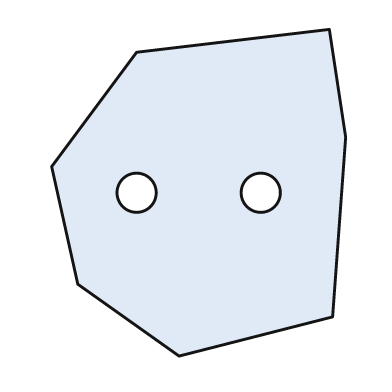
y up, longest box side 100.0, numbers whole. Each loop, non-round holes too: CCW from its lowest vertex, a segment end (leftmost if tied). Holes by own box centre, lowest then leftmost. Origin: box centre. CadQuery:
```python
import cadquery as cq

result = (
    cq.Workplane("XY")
    .moveTo(-6.0, -50.0)
    .lineTo(41.0, -38.0)
    .lineTo(45.0, 17.0)
    .lineTo(40.0, 50.0)
    .lineTo(-19.0, 43.0)
    .lineTo(-45.0, 8.0)
    .lineTo(-37.0, -28.0)
    .close()
    .moveTo(-19.0, 0.0)
    .circle(6.0)
    .moveTo(19.0, 0.0)
    .circle(6.0)
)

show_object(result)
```